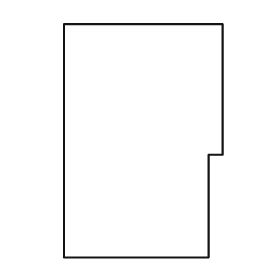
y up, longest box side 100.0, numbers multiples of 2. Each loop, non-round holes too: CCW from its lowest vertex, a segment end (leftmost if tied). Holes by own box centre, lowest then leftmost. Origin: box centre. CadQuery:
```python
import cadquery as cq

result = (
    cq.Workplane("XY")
    .moveTo(-34.0, -50.0)
    .lineTo(28.0, -50.0)
    .lineTo(28.0, -6.0)
    .lineTo(34.0, -6.0)
    .lineTo(34.0, 50.0)
    .lineTo(-34.0, 50.0)
    .close()
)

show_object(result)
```